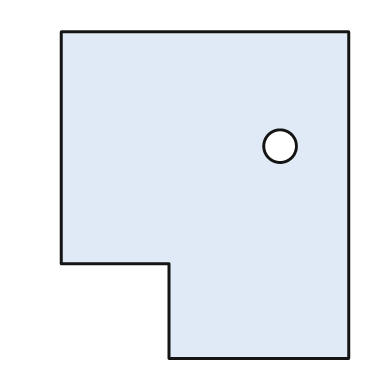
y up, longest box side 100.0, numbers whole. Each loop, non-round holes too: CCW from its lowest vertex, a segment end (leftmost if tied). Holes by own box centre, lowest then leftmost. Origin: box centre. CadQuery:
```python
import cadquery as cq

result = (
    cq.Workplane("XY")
    .moveTo(-11.0, -50.0)
    .lineTo(44.0, -50.0)
    .lineTo(44.0, 50.0)
    .lineTo(-44.0, 50.0)
    .lineTo(-44.0, -21.0)
    .lineTo(-11.0, -21.0)
    .close()
    .moveTo(23.0, 15.0)
    .circle(5.0)
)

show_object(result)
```